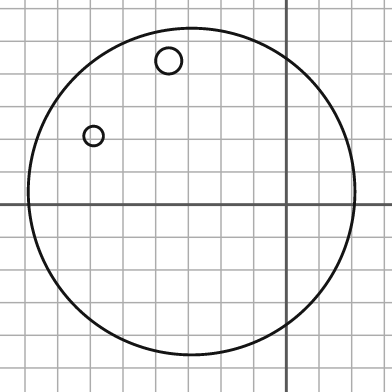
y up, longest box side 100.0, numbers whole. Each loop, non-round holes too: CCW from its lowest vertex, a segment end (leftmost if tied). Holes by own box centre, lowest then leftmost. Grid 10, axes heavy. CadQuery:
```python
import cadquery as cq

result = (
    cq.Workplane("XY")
    .moveTo(-29.0, 4.0)
    .circle(50.0)
    .moveTo(-59.0, 21.0)
    .circle(3.0)
    .moveTo(-36.0, 44.0)
    .circle(4.0)
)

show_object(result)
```